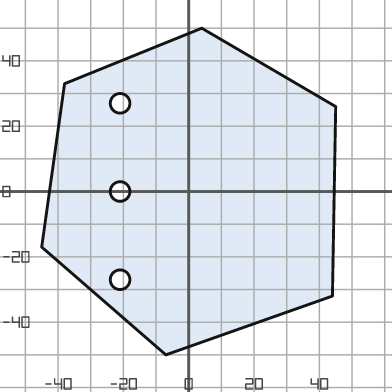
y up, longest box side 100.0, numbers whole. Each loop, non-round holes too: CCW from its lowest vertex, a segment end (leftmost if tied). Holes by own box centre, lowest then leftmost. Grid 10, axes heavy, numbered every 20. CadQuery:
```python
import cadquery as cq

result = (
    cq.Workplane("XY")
    .moveTo(-7.0, -50.0)
    .lineTo(44.0, -32.0)
    .lineTo(45.0, 26.0)
    .lineTo(4.0, 50.0)
    .lineTo(-38.0, 33.0)
    .lineTo(-45.0, -17.0)
    .close()
    .moveTo(-21.0, -27.0)
    .circle(3.0)
    .moveTo(-21.0, 0.0)
    .circle(3.0)
    .moveTo(-21.0, 27.0)
    .circle(3.0)
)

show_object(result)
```